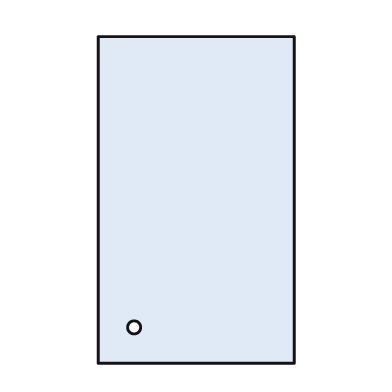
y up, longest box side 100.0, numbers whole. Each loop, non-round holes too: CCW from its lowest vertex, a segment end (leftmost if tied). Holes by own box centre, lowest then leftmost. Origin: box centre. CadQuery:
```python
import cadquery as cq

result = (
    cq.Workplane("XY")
    .moveTo(-30.0, -50.0)
    .lineTo(30.0, -50.0)
    .lineTo(30.0, 50.0)
    .lineTo(-30.0, 50.0)
    .close()
    .moveTo(-19.0, -39.0)
    .circle(2.0)
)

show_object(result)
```